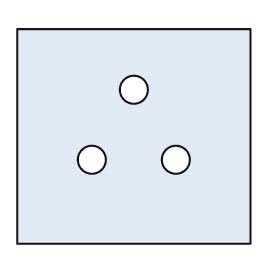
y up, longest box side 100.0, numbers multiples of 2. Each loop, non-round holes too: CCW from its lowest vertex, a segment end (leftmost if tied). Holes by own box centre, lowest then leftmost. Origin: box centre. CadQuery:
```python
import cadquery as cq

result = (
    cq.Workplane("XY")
    .moveTo(-50.0, -46.0)
    .lineTo(50.0, -46.0)
    .lineTo(50.0, 46.0)
    .lineTo(-50.0, 46.0)
    .close()
    .moveTo(-18.0, -10.0)
    .circle(6.0)
    .moveTo(18.0, -10.0)
    .circle(6.0)
    .moveTo(0.0, 20.0)
    .circle(6.0)
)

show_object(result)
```